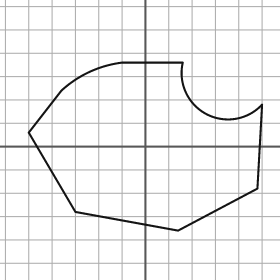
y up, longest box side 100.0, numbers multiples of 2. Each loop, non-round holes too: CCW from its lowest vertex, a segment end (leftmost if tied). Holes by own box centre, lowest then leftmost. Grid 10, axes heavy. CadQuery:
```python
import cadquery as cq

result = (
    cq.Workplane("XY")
    .moveTo(14.0, -36.0)
    .lineTo(48.0, -18.0)
    .lineTo(50.0, 18.0)
    .threePointArc((26.0, 14.0), (16.0, 36.0))
    .lineTo(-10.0, 36.0)
    .threePointArc((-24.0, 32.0), (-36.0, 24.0))
    .lineTo(-50.0, 6.0)
    .lineTo(-30.0, -28.0)
    .close()
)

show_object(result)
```